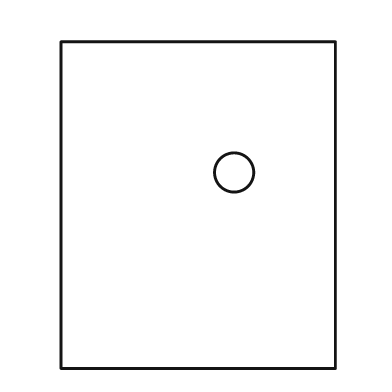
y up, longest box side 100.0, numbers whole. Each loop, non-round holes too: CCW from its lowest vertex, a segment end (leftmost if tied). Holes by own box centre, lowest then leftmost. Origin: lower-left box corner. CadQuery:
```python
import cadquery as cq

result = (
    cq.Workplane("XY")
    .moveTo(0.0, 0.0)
    .lineTo(84.0, 0.0)
    .lineTo(84.0, 100.0)
    .lineTo(0.0, 100.0)
    .close()
    .moveTo(53.0, 60.0)
    .circle(6.0)
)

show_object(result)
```